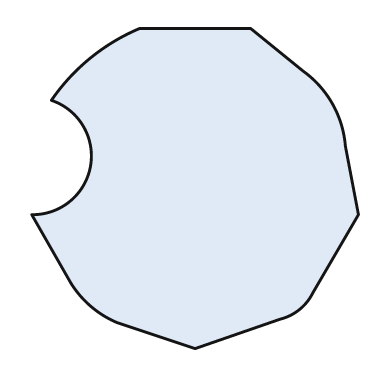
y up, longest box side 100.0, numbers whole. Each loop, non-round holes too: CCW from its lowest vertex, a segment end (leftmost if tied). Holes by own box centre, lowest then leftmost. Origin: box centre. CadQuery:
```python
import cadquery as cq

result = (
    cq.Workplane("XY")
    .moveTo(0.0, -49.0)
    .lineTo(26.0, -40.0)
    .threePointArc((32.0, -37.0), (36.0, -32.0))
    .lineTo(50.0, -8.0)
    .lineTo(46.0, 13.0)
    .threePointArc((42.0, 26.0), (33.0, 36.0))
    .lineTo(17.0, 49.0)
    .lineTo(-17.0, 49.0)
    .threePointArc((-32.0, 40.0), (-44.0, 27.0))
    .threePointArc((-32.0, 7.0), (-50.0, -8.0))
    .lineTo(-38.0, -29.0)
    .threePointArc((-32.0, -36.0), (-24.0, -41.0))
    .close()
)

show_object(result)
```